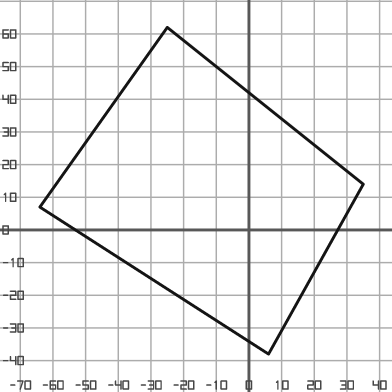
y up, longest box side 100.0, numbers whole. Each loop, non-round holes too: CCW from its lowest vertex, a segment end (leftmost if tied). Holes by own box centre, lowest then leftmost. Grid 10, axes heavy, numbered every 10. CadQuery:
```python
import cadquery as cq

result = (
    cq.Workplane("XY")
    .moveTo(6.0, -38.0)
    .lineTo(35.0, 14.0)
    .lineTo(-25.0, 62.0)
    .lineTo(-64.0, 7.0)
    .close()
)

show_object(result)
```